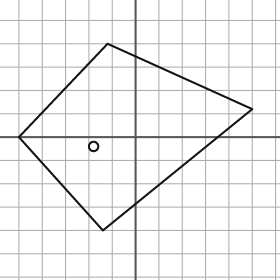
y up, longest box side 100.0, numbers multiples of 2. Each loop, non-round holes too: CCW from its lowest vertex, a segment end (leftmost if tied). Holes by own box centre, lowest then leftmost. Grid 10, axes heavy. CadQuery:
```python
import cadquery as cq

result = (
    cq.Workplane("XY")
    .moveTo(-14.0, -40.0)
    .lineTo(50.0, 12.0)
    .lineTo(-12.0, 40.0)
    .lineTo(-50.0, 0.0)
    .close()
    .moveTo(-18.0, -4.0)
    .circle(2.0)
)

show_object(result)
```